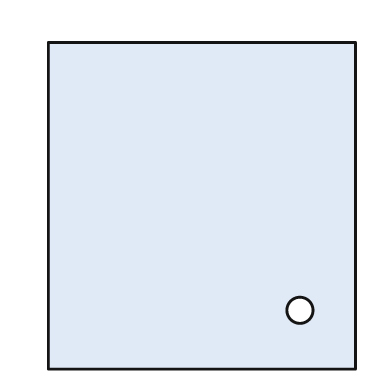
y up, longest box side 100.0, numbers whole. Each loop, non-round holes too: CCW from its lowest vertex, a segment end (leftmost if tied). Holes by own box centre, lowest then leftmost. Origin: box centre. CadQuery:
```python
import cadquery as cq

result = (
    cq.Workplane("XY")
    .moveTo(-47.0, -50.0)
    .lineTo(47.0, -50.0)
    .lineTo(47.0, 50.0)
    .lineTo(-47.0, 50.0)
    .close()
    .moveTo(30.0, -32.0)
    .circle(4.0)
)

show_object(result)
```